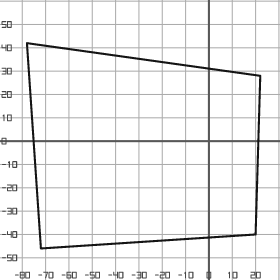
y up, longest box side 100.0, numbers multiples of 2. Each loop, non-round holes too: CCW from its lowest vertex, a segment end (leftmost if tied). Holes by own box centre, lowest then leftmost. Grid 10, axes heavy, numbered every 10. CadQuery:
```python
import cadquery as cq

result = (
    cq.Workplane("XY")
    .moveTo(-72.0, -46.0)
    .lineTo(20.0, -40.0)
    .lineTo(22.0, 28.0)
    .lineTo(-78.0, 42.0)
    .close()
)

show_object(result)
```